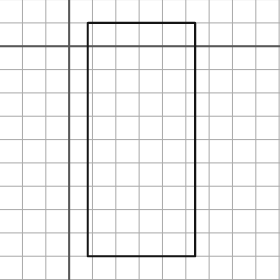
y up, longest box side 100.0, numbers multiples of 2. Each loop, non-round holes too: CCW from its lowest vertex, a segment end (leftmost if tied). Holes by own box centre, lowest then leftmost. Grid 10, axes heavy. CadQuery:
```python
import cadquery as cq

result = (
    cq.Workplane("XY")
    .moveTo(8.0, -90.0)
    .lineTo(54.0, -90.0)
    .lineTo(54.0, 10.0)
    .lineTo(8.0, 10.0)
    .close()
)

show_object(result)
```